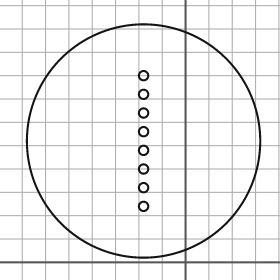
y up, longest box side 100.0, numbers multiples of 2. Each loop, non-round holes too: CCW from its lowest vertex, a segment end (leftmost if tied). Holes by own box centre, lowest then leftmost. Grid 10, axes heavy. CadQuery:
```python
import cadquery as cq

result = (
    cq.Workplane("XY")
    .moveTo(-18.0, 52.0)
    .circle(50.0)
    .moveTo(-18.0, 24.0)
    .circle(2.0)
    .moveTo(-18.0, 32.0)
    .circle(2.0)
    .moveTo(-18.0, 40.0)
    .circle(2.0)
    .moveTo(-18.0, 48.0)
    .circle(2.0)
    .moveTo(-18.0, 56.0)
    .circle(2.0)
    .moveTo(-18.0, 64.0)
    .circle(2.0)
    .moveTo(-18.0, 72.0)
    .circle(2.0)
    .moveTo(-18.0, 80.0)
    .circle(2.0)
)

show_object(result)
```